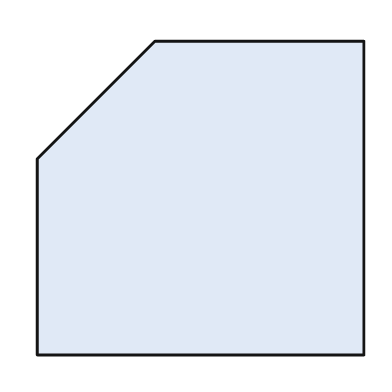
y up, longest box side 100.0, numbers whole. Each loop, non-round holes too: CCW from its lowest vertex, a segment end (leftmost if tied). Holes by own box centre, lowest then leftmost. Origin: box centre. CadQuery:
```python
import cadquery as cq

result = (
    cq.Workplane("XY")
    .moveTo(-50.0, -48.0)
    .lineTo(50.0, -48.0)
    .lineTo(50.0, 48.0)
    .lineTo(-14.0, 48.0)
    .lineTo(-50.0, 12.0)
    .close()
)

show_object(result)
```